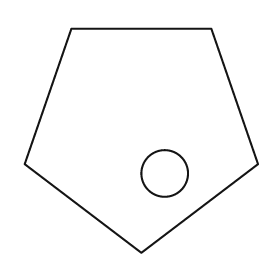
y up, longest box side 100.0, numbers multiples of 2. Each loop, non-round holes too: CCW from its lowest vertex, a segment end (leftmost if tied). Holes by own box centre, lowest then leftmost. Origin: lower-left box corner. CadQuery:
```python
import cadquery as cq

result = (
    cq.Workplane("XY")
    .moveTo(50.0, 0.0)
    .lineTo(100.0, 38.0)
    .lineTo(80.0, 96.0)
    .lineTo(20.0, 96.0)
    .lineTo(0.0, 38.0)
    .close()
    .moveTo(60.0, 34.0)
    .circle(10.0)
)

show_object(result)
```